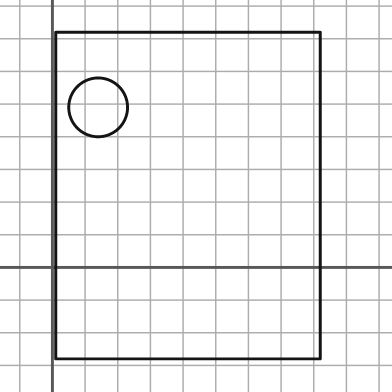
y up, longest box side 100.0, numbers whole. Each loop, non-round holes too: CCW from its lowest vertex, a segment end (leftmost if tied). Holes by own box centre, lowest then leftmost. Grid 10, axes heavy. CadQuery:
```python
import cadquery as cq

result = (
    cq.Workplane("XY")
    .moveTo(1.0, -28.0)
    .lineTo(82.0, -28.0)
    .lineTo(82.0, 72.0)
    .lineTo(1.0, 72.0)
    .close()
    .moveTo(14.0, 49.0)
    .circle(9.0)
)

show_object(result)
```